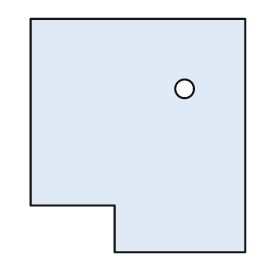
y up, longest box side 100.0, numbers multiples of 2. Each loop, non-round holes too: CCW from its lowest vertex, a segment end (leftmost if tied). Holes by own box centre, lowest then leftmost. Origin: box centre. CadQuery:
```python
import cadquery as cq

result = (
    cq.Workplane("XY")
    .moveTo(-10.0, -50.0)
    .lineTo(46.0, -50.0)
    .lineTo(46.0, 50.0)
    .lineTo(-46.0, 50.0)
    .lineTo(-46.0, -30.0)
    .lineTo(-10.0, -30.0)
    .close()
    .moveTo(20.0, 20.0)
    .circle(4.0)
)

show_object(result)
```